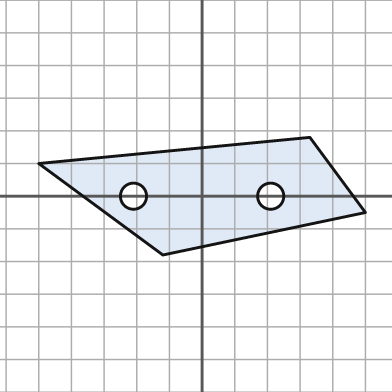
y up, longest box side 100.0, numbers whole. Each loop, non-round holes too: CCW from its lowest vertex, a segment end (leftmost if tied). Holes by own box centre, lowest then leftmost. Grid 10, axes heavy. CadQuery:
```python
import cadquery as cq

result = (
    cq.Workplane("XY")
    .moveTo(-12.0, -18.0)
    .lineTo(50.0, -5.0)
    .lineTo(33.0, 18.0)
    .lineTo(-50.0, 10.0)
    .close()
    .moveTo(-21.0, 0.0)
    .circle(4.0)
    .moveTo(21.0, 0.0)
    .circle(4.0)
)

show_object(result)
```